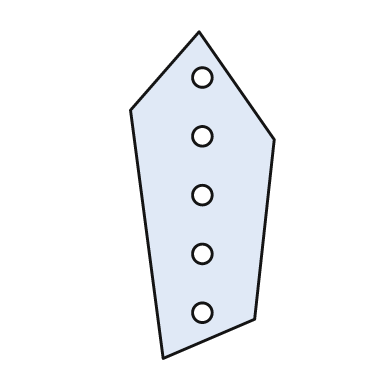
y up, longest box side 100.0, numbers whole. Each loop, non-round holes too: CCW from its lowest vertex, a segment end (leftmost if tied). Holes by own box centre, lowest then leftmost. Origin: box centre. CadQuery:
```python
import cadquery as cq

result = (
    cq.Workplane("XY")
    .moveTo(-12.0, -50.0)
    .lineTo(16.0, -38.0)
    .lineTo(22.0, 17.0)
    .lineTo(-1.0, 50.0)
    .lineTo(-22.0, 26.0)
    .close()
    .moveTo(0.0, -36.0)
    .circle(3.0)
    .moveTo(0.0, -18.0)
    .circle(3.0)
    .moveTo(0.0, 0.0)
    .circle(3.0)
    .moveTo(0.0, 18.0)
    .circle(3.0)
    .moveTo(0.0, 36.0)
    .circle(3.0)
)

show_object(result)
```